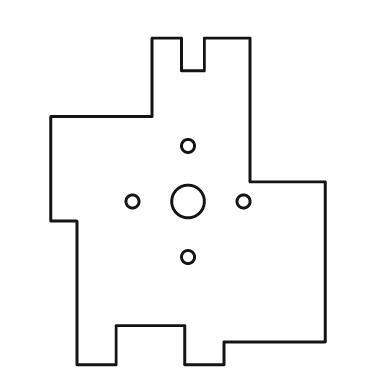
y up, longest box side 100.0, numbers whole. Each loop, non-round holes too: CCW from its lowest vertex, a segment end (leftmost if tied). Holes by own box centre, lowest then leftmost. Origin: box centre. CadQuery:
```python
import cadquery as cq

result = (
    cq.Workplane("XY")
    .moveTo(-34.0, -50.0)
    .lineTo(-22.0, -50.0)
    .lineTo(-22.0, -38.0)
    .lineTo(-1.0, -38.0)
    .lineTo(-1.0, -50.0)
    .lineTo(11.0, -50.0)
    .lineTo(11.0, -43.0)
    .lineTo(42.0, -43.0)
    .lineTo(42.0, 6.0)
    .lineTo(19.0, 6.0)
    .lineTo(19.0, 50.0)
    .lineTo(5.0, 50.0)
    .lineTo(5.0, 40.0)
    .lineTo(-2.0, 40.0)
    .lineTo(-2.0, 50.0)
    .lineTo(-11.0, 50.0)
    .lineTo(-11.0, 26.0)
    .lineTo(-42.0, 26.0)
    .lineTo(-42.0, -6.0)
    .lineTo(-34.0, -6.0)
    .close()
    .moveTo(0.0, -17.0)
    .circle(2.0)
    .moveTo(-17.0, 0.0)
    .circle(2.0)
    .moveTo(0.0, 0.0)
    .circle(5.0)
    .moveTo(17.0, 0.0)
    .circle(2.0)
    .moveTo(0.0, 17.0)
    .circle(2.0)
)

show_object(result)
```